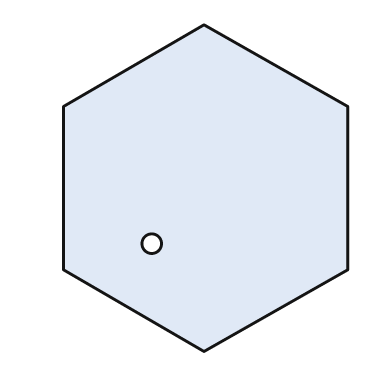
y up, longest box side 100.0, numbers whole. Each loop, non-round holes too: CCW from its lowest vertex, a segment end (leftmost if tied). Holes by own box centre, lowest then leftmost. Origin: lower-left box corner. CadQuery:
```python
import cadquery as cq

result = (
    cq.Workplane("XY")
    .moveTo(43.0, 0.0)
    .lineTo(87.0, 25.0)
    .lineTo(87.0, 75.0)
    .lineTo(43.0, 100.0)
    .lineTo(0.0, 75.0)
    .lineTo(0.0, 25.0)
    .close()
    .moveTo(27.0, 33.0)
    .circle(3.0)
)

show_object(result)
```